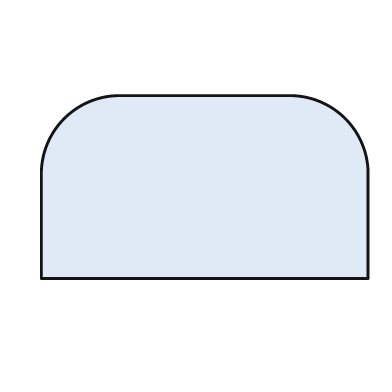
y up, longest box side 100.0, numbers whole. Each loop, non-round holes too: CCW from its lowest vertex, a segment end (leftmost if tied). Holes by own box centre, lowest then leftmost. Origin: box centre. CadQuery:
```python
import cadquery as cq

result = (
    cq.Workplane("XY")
    .moveTo(-50.0, -28.0)
    .lineTo(50.0, -28.0)
    .lineTo(50.0, 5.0)
    .threePointArc((43.0, 21.0), (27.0, 28.0))
    .lineTo(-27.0, 28.0)
    .threePointArc((-43.0, 21.0), (-50.0, 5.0))
    .close()
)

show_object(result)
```